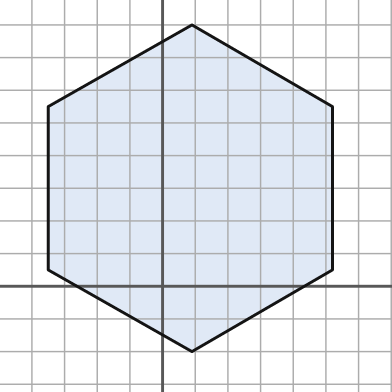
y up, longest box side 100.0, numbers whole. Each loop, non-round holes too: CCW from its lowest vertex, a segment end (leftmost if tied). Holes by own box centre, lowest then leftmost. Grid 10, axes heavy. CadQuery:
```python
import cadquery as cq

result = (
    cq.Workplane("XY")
    .moveTo(9.0, -20.0)
    .lineTo(52.0, 5.0)
    .lineTo(52.0, 55.0)
    .lineTo(9.0, 80.0)
    .lineTo(-35.0, 55.0)
    .lineTo(-35.0, 5.0)
    .close()
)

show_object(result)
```